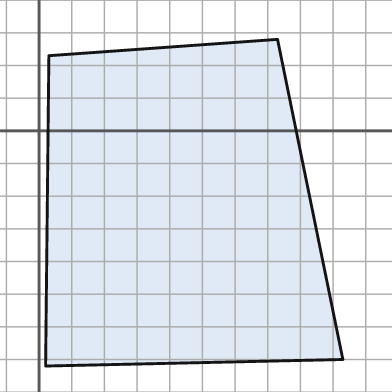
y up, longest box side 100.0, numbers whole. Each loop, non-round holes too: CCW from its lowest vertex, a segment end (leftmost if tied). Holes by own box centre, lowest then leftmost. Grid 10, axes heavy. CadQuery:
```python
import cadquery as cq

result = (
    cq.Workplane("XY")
    .moveTo(2.0, -72.0)
    .lineTo(93.0, -70.0)
    .lineTo(73.0, 28.0)
    .lineTo(3.0, 23.0)
    .close()
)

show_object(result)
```